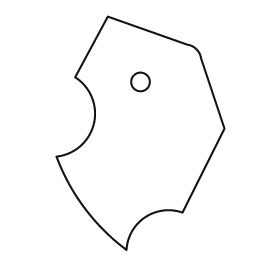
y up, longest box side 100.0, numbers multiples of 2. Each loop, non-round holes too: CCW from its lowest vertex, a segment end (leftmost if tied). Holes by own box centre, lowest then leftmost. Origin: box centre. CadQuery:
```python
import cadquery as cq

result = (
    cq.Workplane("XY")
    .moveTo(-6.0, -50.0)
    .threePointArc((2.0, -36.0), (18.0, -34.0))
    .lineTo(36.0, 2.0)
    .lineTo(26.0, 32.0)
    .threePointArc((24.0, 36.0), (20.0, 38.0))
    .lineTo(-14.0, 50.0)
    .lineTo(-28.0, 24.0)
    .threePointArc((-20.0, 4.0), (-36.0, -10.0))
    .threePointArc((-24.0, -32.0), (-6.0, -50.0))
    .close()
    .moveTo(0.0, 22.0)
    .circle(4.0)
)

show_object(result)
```